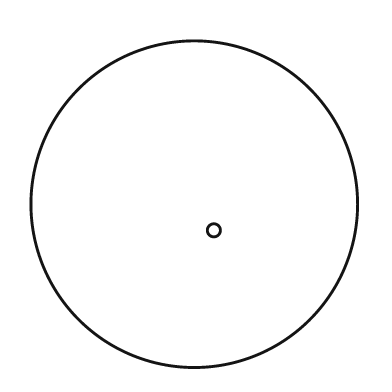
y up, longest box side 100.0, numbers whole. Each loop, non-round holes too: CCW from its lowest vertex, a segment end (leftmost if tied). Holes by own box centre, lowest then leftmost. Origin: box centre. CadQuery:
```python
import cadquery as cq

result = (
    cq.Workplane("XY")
    .moveTo(0.0, 0.0)
    .circle(50.0)
    .moveTo(6.0, -8.0)
    .circle(2.0)
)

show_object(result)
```